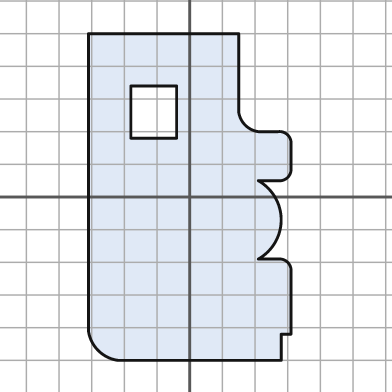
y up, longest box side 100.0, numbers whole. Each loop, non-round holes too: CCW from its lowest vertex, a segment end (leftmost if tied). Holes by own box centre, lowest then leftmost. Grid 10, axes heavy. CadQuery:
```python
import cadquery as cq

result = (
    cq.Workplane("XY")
    .moveTo(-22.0, -50.0)
    .lineTo(28.0, -50.0)
    .lineTo(28.0, -42.0)
    .lineTo(31.0, -42.0)
    .lineTo(31.0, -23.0)
    .threePointArc((30.0, -20.0), (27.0, -19.0))
    .lineTo(21.0, -19.0)
    .threePointArc((28.0, -7.0), (21.0, 5.0))
    .lineTo(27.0, 5.0)
    .threePointArc((30.0, 6.0), (31.0, 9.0))
    .lineTo(31.0, 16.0)
    .threePointArc((30.0, 19.0), (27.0, 20.0))
    .lineTo(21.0, 20.0)
    .threePointArc((17.0, 22.0), (15.0, 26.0))
    .lineTo(15.0, 50.0)
    .lineTo(-31.0, 50.0)
    .lineTo(-31.0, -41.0)
    .threePointArc((-28.0, -47.0), (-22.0, -50.0))
    .close()
    .moveTo(-18.0, 18.0)
    .lineTo(-4.0, 18.0)
    .lineTo(-4.0, 34.0)
    .lineTo(-18.0, 34.0)
    .close()
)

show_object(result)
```